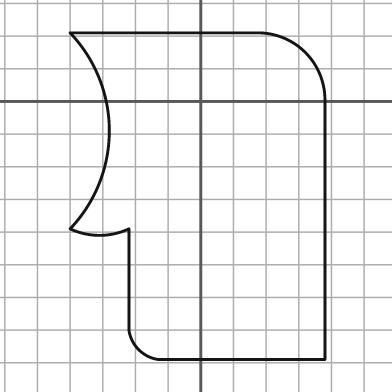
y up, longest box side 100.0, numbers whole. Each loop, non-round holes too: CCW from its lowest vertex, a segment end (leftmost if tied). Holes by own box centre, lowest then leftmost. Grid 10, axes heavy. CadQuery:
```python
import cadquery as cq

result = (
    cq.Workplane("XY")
    .moveTo(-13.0, -79.0)
    .lineTo(38.0, -79.0)
    .lineTo(38.0, 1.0)
    .threePointArc((32.0, 15.0), (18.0, 21.0))
    .lineTo(-40.0, 21.0)
    .threePointArc((-28.0, -9.0), (-40.0, -39.0))
    .threePointArc((-31.0, -41.0), (-22.0, -39.0))
    .lineTo(-22.0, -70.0)
    .threePointArc((-19.0, -76.0), (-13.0, -79.0))
    .close()
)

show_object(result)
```